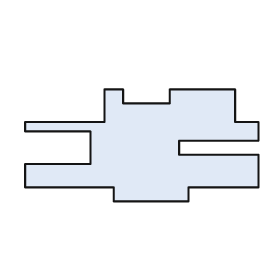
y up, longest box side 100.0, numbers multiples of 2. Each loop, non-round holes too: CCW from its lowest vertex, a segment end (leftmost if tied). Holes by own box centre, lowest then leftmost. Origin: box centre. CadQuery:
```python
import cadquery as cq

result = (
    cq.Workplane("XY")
    .moveTo(-12.0, -24.0)
    .lineTo(20.0, -24.0)
    .lineTo(20.0, -18.0)
    .lineTo(50.0, -18.0)
    .lineTo(50.0, -4.0)
    .lineTo(16.0, -4.0)
    .lineTo(16.0, 2.0)
    .lineTo(50.0, 2.0)
    .lineTo(50.0, 10.0)
    .lineTo(40.0, 10.0)
    .lineTo(40.0, 24.0)
    .lineTo(12.0, 24.0)
    .lineTo(12.0, 18.0)
    .lineTo(-8.0, 18.0)
    .lineTo(-8.0, 24.0)
    .lineTo(-16.0, 24.0)
    .lineTo(-16.0, 10.0)
    .lineTo(-50.0, 10.0)
    .lineTo(-50.0, 6.0)
    .lineTo(-22.0, 6.0)
    .lineTo(-22.0, -8.0)
    .lineTo(-50.0, -8.0)
    .lineTo(-50.0, -18.0)
    .lineTo(-12.0, -18.0)
    .close()
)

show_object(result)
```